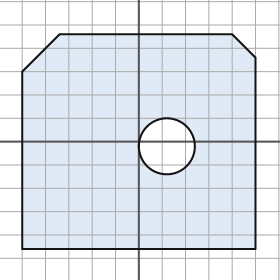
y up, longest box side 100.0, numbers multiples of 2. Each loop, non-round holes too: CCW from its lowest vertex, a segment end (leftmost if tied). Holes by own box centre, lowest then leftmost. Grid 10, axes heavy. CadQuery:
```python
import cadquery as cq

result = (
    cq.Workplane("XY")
    .moveTo(-50.0, -46.0)
    .lineTo(50.0, -46.0)
    .lineTo(50.0, 36.0)
    .lineTo(40.0, 46.0)
    .lineTo(-34.0, 46.0)
    .lineTo(-50.0, 30.0)
    .close()
    .moveTo(12.0, -2.0)
    .circle(12.0)
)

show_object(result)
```